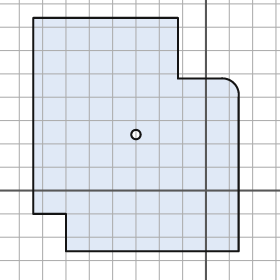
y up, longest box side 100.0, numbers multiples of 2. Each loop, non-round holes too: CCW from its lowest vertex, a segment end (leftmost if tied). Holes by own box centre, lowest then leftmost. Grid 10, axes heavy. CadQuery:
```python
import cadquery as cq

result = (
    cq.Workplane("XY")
    .moveTo(-60.0, -26.0)
    .lineTo(14.0, -26.0)
    .lineTo(14.0, 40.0)
    .threePointArc((12.0, 46.0), (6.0, 48.0))
    .lineTo(-12.0, 48.0)
    .lineTo(-12.0, 74.0)
    .lineTo(-74.0, 74.0)
    .lineTo(-74.0, -10.0)
    .lineTo(-60.0, -10.0)
    .close()
    .moveTo(-30.0, 24.0)
    .circle(2.0)
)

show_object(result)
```